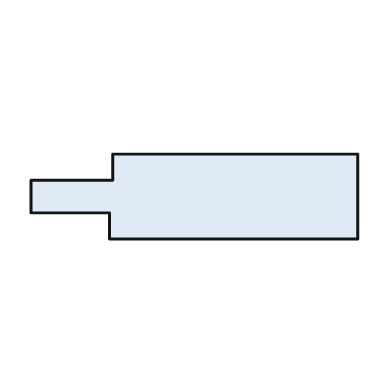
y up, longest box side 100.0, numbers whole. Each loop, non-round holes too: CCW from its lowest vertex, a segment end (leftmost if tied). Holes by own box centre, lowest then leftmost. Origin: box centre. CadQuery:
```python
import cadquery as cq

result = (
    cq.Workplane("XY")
    .moveTo(-26.0, -13.0)
    .lineTo(50.0, -13.0)
    .lineTo(50.0, 13.0)
    .lineTo(-25.0, 13.0)
    .lineTo(-25.0, 5.0)
    .lineTo(-50.0, 5.0)
    .lineTo(-50.0, -5.0)
    .lineTo(-26.0, -5.0)
    .close()
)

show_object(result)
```